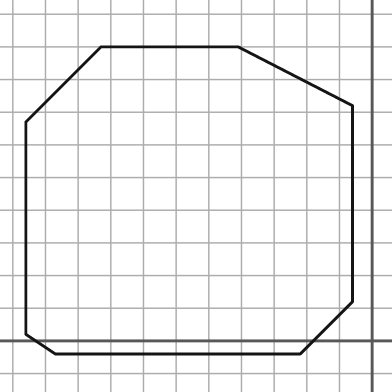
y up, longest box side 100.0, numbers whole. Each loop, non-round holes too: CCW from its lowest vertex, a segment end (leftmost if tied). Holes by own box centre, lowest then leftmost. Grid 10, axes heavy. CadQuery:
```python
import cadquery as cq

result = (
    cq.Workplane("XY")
    .moveTo(-97.0, -4.0)
    .lineTo(-22.0, -4.0)
    .lineTo(-6.0, 12.0)
    .lineTo(-6.0, 72.0)
    .lineTo(-41.0, 90.0)
    .lineTo(-83.0, 90.0)
    .lineTo(-106.0, 67.0)
    .lineTo(-106.0, 2.0)
    .close()
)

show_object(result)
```